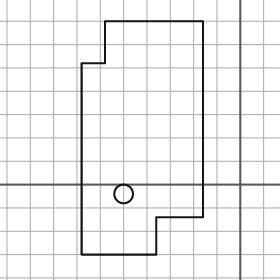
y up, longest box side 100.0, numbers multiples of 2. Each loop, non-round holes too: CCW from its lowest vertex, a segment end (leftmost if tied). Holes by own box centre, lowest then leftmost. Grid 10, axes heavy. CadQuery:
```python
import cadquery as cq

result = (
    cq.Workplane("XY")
    .moveTo(-68.0, -30.0)
    .lineTo(-36.0, -30.0)
    .lineTo(-36.0, -14.0)
    .lineTo(-16.0, -14.0)
    .lineTo(-16.0, 70.0)
    .lineTo(-58.0, 70.0)
    .lineTo(-58.0, 52.0)
    .lineTo(-68.0, 52.0)
    .close()
    .moveTo(-50.0, -4.0)
    .circle(4.0)
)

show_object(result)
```